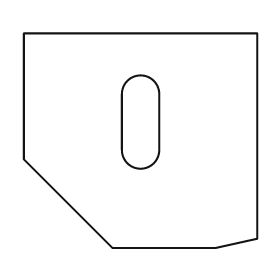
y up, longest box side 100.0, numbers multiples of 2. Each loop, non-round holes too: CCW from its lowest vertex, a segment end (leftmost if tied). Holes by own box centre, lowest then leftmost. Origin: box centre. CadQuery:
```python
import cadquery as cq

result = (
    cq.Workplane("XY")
    .moveTo(-12.0, -46.0)
    .lineTo(32.0, -46.0)
    .lineTo(50.0, -42.0)
    .lineTo(50.0, 46.0)
    .lineTo(-50.0, 46.0)
    .lineTo(-50.0, -8.0)
    .close()
    .moveTo(-8.0, -4.0)
    .threePointArc((0.0, -12.0), (8.0, -4.0))
    .lineTo(8.0, 20.0)
    .threePointArc((0.0, 28.0), (-8.0, 20.0))
    .close()
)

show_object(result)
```